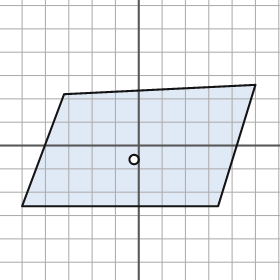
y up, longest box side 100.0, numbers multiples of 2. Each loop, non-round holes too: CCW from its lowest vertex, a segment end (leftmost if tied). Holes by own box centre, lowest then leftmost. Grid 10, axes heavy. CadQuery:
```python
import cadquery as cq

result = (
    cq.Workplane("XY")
    .moveTo(-50.0, -26.0)
    .lineTo(34.0, -26.0)
    .lineTo(50.0, 26.0)
    .lineTo(-32.0, 22.0)
    .close()
    .moveTo(-2.0, -6.0)
    .circle(2.0)
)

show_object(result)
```